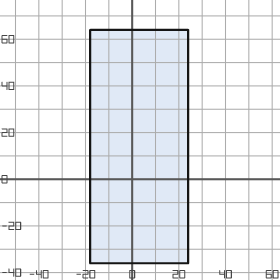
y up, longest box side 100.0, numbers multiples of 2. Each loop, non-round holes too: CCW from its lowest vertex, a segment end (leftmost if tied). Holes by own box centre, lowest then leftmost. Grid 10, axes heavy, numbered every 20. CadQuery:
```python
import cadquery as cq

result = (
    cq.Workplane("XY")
    .moveTo(-18.0, -36.0)
    .lineTo(24.0, -36.0)
    .lineTo(24.0, 64.0)
    .lineTo(-18.0, 64.0)
    .close()
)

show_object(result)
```